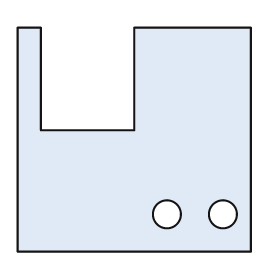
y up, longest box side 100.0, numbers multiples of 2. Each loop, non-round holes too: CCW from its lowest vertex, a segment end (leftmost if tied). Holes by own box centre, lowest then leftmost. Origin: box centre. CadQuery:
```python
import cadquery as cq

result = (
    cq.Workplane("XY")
    .moveTo(-50.0, -48.0)
    .lineTo(50.0, -48.0)
    .lineTo(50.0, 48.0)
    .lineTo(0.0, 48.0)
    .lineTo(0.0, 4.0)
    .lineTo(-40.0, 4.0)
    .lineTo(-40.0, 48.0)
    .lineTo(-50.0, 48.0)
    .close()
    .moveTo(14.0, -32.0)
    .circle(6.0)
    .moveTo(38.0, -32.0)
    .circle(6.0)
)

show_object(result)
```